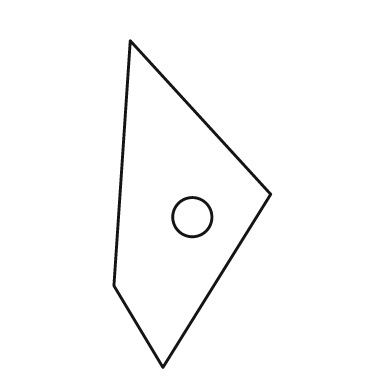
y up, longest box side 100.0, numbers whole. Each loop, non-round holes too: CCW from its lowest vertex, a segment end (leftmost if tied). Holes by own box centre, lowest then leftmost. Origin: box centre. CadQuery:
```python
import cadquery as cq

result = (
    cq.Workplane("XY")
    .moveTo(-9.0, -50.0)
    .lineTo(24.0, 3.0)
    .lineTo(-19.0, 50.0)
    .lineTo(-24.0, -25.0)
    .close()
    .moveTo(0.0, -4.0)
    .circle(6.0)
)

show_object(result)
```